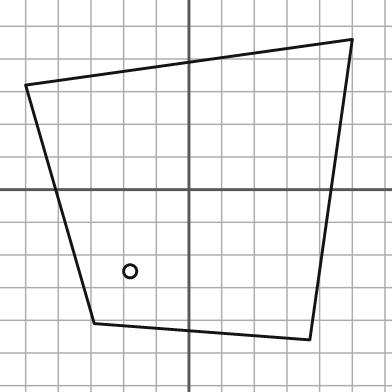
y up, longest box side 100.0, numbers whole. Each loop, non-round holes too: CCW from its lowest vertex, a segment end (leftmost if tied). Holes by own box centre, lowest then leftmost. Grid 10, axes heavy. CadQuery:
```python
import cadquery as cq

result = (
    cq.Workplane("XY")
    .moveTo(37.0, -46.0)
    .lineTo(50.0, 46.0)
    .lineTo(-50.0, 32.0)
    .lineTo(-29.0, -41.0)
    .close()
    .moveTo(-18.0, -25.0)
    .circle(2.0)
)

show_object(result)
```